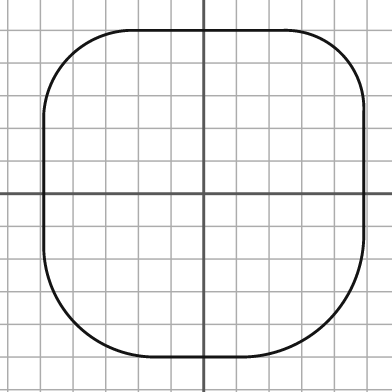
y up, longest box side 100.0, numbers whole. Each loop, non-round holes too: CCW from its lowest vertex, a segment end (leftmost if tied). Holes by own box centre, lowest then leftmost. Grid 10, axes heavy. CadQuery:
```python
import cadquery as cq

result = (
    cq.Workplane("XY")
    .moveTo(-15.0, -50.0)
    .lineTo(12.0, -50.0)
    .threePointArc((38.0, -39.0), (49.0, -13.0))
    .lineTo(49.0, 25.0)
    .threePointArc((42.0, 43.0), (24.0, 50.0))
    .lineTo(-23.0, 50.0)
    .threePointArc((-41.0, 42.0), (-49.0, 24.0))
    .lineTo(-49.0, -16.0)
    .threePointArc((-39.0, -40.0), (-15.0, -50.0))
    .close()
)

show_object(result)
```